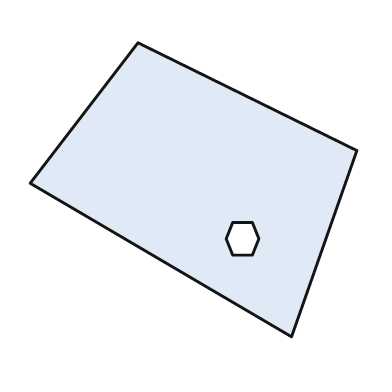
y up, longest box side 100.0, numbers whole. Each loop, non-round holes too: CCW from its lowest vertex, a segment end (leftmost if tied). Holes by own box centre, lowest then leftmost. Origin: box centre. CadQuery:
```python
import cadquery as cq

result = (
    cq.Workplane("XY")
    .moveTo(30.0, -45.0)
    .lineTo(50.0, 12.0)
    .lineTo(-17.0, 45.0)
    .lineTo(-50.0, 2.0)
    .close()
    .moveTo(12.0, -20.0)
    .lineTo(18.0, -20.0)
    .lineTo(20.0, -15.0)
    .lineTo(18.0, -10.0)
    .lineTo(12.0, -10.0)
    .lineTo(10.0, -15.0)
    .close()
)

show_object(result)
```